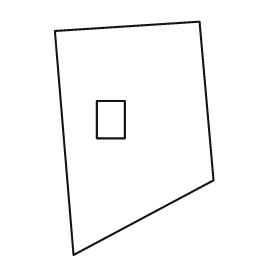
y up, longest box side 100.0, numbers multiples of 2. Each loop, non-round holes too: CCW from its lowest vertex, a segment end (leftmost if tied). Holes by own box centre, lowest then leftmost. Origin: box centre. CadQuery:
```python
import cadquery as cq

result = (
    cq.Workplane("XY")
    .moveTo(-26.0, -50.0)
    .lineTo(34.0, -18.0)
    .lineTo(28.0, 50.0)
    .lineTo(-34.0, 46.0)
    .close()
    .moveTo(-16.0, 0.0)
    .lineTo(-4.0, 0.0)
    .lineTo(-4.0, 16.0)
    .lineTo(-16.0, 16.0)
    .close()
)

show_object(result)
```